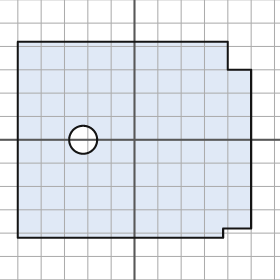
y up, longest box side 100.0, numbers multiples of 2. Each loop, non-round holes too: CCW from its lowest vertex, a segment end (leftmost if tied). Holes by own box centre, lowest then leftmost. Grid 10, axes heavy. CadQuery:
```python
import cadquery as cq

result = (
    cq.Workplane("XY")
    .moveTo(-50.0, -42.0)
    .lineTo(38.0, -42.0)
    .lineTo(38.0, -38.0)
    .lineTo(50.0, -38.0)
    .lineTo(50.0, 30.0)
    .lineTo(40.0, 30.0)
    .lineTo(40.0, 42.0)
    .lineTo(-50.0, 42.0)
    .close()
    .moveTo(-22.0, 0.0)
    .circle(6.0)
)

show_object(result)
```